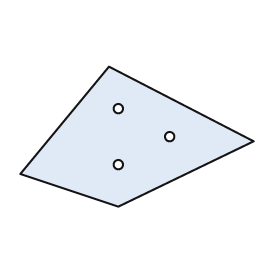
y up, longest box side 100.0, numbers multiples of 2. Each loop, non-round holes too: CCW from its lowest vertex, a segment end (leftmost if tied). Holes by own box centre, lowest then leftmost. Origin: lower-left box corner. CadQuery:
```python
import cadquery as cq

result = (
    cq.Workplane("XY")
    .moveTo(42.0, 0.0)
    .lineTo(100.0, 28.0)
    .lineTo(38.0, 60.0)
    .lineTo(0.0, 14.0)
    .close()
    .moveTo(42.0, 18.0)
    .circle(2.0)
    .moveTo(64.0, 30.0)
    .circle(2.0)
    .moveTo(42.0, 42.0)
    .circle(2.0)
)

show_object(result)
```